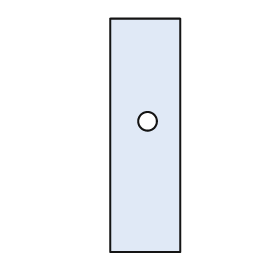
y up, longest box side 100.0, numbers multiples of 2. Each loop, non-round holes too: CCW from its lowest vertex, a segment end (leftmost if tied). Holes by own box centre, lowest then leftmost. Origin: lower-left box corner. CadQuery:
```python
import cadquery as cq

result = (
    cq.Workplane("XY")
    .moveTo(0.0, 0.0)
    .lineTo(30.0, 0.0)
    .lineTo(30.0, 100.0)
    .lineTo(0.0, 100.0)
    .close()
    .moveTo(16.0, 56.0)
    .circle(4.0)
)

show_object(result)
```